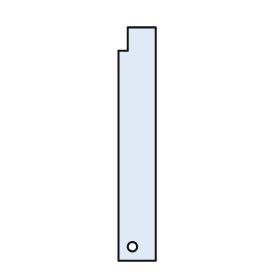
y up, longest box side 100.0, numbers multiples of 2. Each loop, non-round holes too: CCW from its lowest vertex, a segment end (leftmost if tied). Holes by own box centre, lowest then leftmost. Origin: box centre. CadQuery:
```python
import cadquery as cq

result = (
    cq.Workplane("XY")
    .moveTo(-8.0, -50.0)
    .lineTo(8.0, -50.0)
    .lineTo(8.0, 50.0)
    .lineTo(-4.0, 50.0)
    .lineTo(-4.0, 40.0)
    .lineTo(-8.0, 40.0)
    .close()
    .moveTo(-2.0, -44.0)
    .circle(2.0)
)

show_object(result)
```